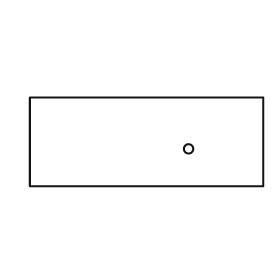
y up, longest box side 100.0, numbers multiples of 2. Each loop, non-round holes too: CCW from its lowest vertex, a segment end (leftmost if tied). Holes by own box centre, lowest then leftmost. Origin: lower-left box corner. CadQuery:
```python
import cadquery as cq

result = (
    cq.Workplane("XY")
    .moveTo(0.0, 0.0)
    .lineTo(100.0, 0.0)
    .lineTo(100.0, 38.0)
    .lineTo(0.0, 38.0)
    .close()
    .moveTo(68.0, 16.0)
    .circle(2.0)
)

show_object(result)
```